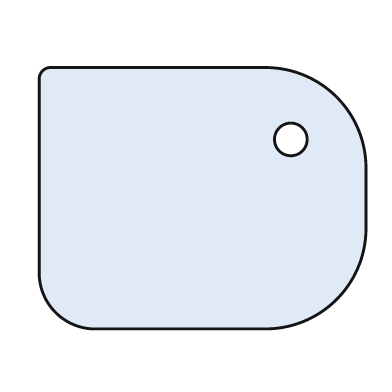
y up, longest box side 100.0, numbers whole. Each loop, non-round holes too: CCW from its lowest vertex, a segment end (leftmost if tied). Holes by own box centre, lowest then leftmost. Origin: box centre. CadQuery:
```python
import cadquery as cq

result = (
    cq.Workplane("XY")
    .moveTo(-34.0, -40.0)
    .lineTo(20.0, -40.0)
    .threePointArc((41.0, -31.0), (50.0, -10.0))
    .lineTo(50.0, 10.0)
    .threePointArc((41.0, 31.0), (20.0, 40.0))
    .lineTo(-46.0, 40.0)
    .threePointArc((-49.0, 39.0), (-50.0, 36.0))
    .lineTo(-50.0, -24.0)
    .threePointArc((-45.0, -35.0), (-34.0, -40.0))
    .close()
    .moveTo(27.0, 18.0)
    .circle(5.0)
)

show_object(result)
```